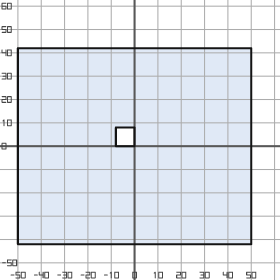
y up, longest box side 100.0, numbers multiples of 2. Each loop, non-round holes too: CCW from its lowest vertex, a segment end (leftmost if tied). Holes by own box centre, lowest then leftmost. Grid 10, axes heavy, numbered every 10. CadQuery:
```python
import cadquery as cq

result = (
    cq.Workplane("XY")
    .moveTo(-50.0, -42.0)
    .lineTo(50.0, -42.0)
    .lineTo(50.0, 42.0)
    .lineTo(-50.0, 42.0)
    .close()
    .moveTo(-8.0, 0.0)
    .lineTo(0.0, 0.0)
    .lineTo(0.0, 8.0)
    .lineTo(-8.0, 8.0)
    .close()
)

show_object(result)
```